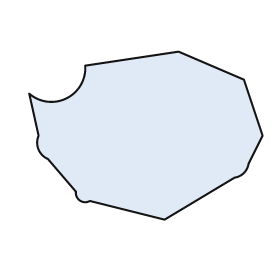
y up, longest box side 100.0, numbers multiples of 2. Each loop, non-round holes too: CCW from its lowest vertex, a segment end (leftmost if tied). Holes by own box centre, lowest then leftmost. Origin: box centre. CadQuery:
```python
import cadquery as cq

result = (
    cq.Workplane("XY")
    .moveTo(8.0, -36.0)
    .lineTo(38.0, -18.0)
    .threePointArc((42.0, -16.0), (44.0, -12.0))
    .lineTo(50.0, 0.0)
    .lineTo(42.0, 24.0)
    .lineTo(14.0, 36.0)
    .lineTo(-26.0, 30.0)
    .threePointArc((-34.0, 16.0), (-50.0, 18.0))
    .lineTo(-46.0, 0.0)
    .threePointArc((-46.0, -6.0), (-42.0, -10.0))
    .lineTo(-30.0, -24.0)
    .threePointArc((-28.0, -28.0), (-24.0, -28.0))
    .close()
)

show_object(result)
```